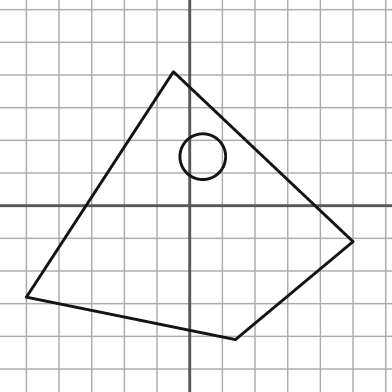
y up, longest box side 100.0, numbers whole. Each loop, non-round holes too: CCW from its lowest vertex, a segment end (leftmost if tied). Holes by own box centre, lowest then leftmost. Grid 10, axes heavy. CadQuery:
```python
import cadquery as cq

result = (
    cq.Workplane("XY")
    .moveTo(14.0, -41.0)
    .lineTo(50.0, -11.0)
    .lineTo(-5.0, 41.0)
    .lineTo(-50.0, -28.0)
    .close()
    .moveTo(4.0, 15.0)
    .circle(7.0)
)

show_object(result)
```